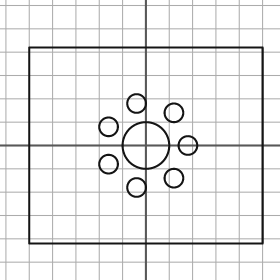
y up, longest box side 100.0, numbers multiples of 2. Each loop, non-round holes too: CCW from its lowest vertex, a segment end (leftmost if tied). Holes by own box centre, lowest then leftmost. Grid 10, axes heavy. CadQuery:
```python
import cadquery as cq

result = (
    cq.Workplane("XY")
    .moveTo(-50.0, -42.0)
    .lineTo(50.0, -42.0)
    .lineTo(50.0, 42.0)
    .lineTo(-50.0, 42.0)
    .close()
    .moveTo(-4.0, -18.0)
    .circle(4.0)
    .moveTo(12.0, -14.0)
    .circle(4.0)
    .moveTo(-16.0, -8.0)
    .circle(4.0)
    .moveTo(0.0, 0.0)
    .circle(10.0)
    .moveTo(18.0, 0.0)
    .circle(4.0)
    .moveTo(-16.0, 8.0)
    .circle(4.0)
    .moveTo(12.0, 14.0)
    .circle(4.0)
    .moveTo(-4.0, 18.0)
    .circle(4.0)
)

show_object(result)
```